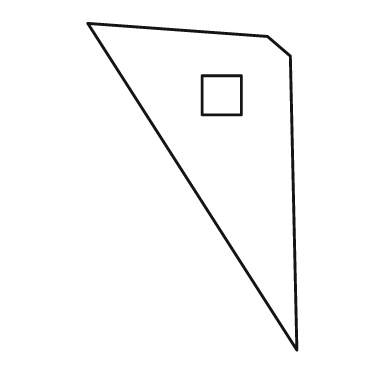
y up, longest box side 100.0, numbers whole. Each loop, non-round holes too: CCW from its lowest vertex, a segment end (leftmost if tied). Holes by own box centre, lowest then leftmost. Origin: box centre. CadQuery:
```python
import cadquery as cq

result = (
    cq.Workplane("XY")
    .moveTo(32.0, -50.0)
    .lineTo(30.0, 40.0)
    .lineTo(23.0, 46.0)
    .lineTo(-32.0, 50.0)
    .close()
    .moveTo(3.0, 22.0)
    .lineTo(15.0, 22.0)
    .lineTo(15.0, 34.0)
    .lineTo(3.0, 34.0)
    .close()
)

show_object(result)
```